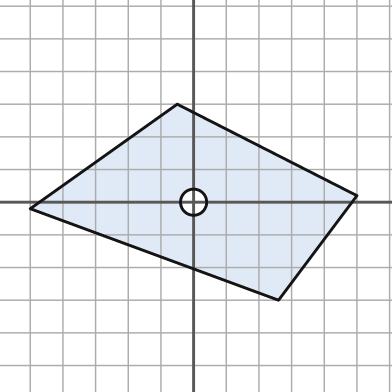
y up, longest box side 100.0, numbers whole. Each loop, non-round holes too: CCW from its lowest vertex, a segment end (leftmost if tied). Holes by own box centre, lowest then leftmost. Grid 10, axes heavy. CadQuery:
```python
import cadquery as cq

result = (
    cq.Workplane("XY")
    .moveTo(26.0, -30.0)
    .lineTo(50.0, 2.0)
    .lineTo(-5.0, 30.0)
    .lineTo(-50.0, -2.0)
    .close()
    .moveTo(0.0, 0.0)
    .circle(4.0)
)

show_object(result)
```